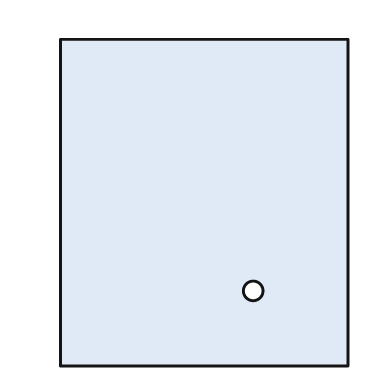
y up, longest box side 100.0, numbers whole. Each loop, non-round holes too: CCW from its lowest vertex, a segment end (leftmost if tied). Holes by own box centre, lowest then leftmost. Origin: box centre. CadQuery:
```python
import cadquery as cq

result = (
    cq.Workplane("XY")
    .moveTo(-44.0, -50.0)
    .lineTo(44.0, -50.0)
    .lineTo(44.0, 50.0)
    .lineTo(-44.0, 50.0)
    .close()
    .moveTo(15.0, -27.0)
    .circle(3.0)
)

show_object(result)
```